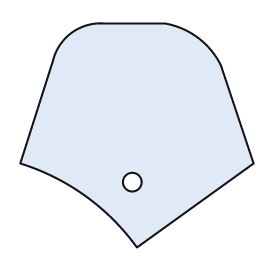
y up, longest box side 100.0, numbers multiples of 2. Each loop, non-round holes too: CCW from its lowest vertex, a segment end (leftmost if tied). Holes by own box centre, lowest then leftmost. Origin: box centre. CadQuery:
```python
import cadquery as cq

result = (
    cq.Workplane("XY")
    .moveTo(0.0, -48.0)
    .lineTo(50.0, -12.0)
    .lineTo(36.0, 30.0)
    .threePointArc((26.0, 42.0), (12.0, 48.0))
    .lineTo(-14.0, 48.0)
    .threePointArc((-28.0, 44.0), (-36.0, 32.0))
    .lineTo(-50.0, -12.0)
    .threePointArc((-22.0, -26.0), (0.0, -48.0))
    .close()
    .moveTo(-2.0, -20.0)
    .circle(4.0)
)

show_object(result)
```